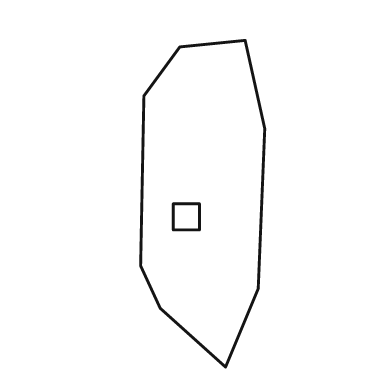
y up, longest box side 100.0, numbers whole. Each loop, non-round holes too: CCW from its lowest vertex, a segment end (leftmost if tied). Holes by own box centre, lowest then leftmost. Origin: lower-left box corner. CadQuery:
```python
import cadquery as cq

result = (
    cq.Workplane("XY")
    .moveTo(26.0, 0.0)
    .lineTo(36.0, 24.0)
    .lineTo(38.0, 73.0)
    .lineTo(32.0, 100.0)
    .lineTo(12.0, 98.0)
    .lineTo(1.0, 83.0)
    .lineTo(0.0, 31.0)
    .lineTo(6.0, 18.0)
    .close()
    .moveTo(10.0, 42.0)
    .lineTo(18.0, 42.0)
    .lineTo(18.0, 50.0)
    .lineTo(10.0, 50.0)
    .close()
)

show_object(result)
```